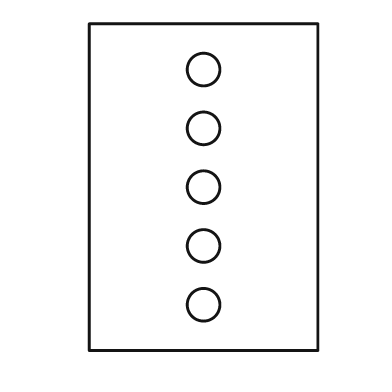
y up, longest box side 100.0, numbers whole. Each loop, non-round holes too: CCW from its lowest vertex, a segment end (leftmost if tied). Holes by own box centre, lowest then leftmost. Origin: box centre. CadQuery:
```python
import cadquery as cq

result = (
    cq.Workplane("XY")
    .moveTo(-35.0, -50.0)
    .lineTo(35.0, -50.0)
    .lineTo(35.0, 50.0)
    .lineTo(-35.0, 50.0)
    .close()
    .moveTo(0.0, -36.0)
    .circle(5.0)
    .moveTo(0.0, -18.0)
    .circle(5.0)
    .moveTo(0.0, 0.0)
    .circle(5.0)
    .moveTo(0.0, 18.0)
    .circle(5.0)
    .moveTo(0.0, 36.0)
    .circle(5.0)
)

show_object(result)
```